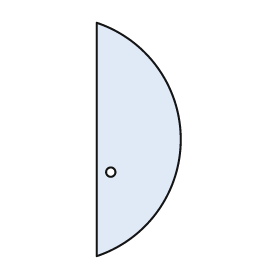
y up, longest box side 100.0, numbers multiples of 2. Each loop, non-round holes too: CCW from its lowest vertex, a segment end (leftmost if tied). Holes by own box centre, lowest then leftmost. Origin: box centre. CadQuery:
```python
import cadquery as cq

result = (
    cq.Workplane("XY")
    .moveTo(-18.0, -50.0)
    .threePointArc((18.0, 0.0), (-18.0, 50.0))
    .close()
    .moveTo(-12.0, -14.0)
    .circle(2.0)
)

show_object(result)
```